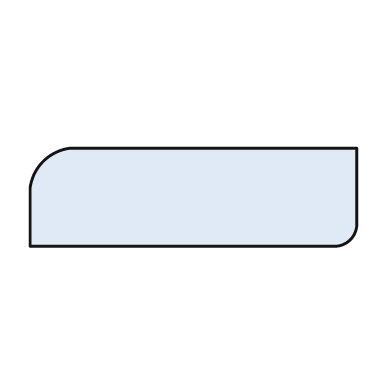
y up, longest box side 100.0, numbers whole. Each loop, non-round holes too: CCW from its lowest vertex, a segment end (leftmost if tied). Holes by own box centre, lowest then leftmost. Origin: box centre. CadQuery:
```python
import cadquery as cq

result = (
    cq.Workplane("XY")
    .moveTo(-50.0, -15.0)
    .lineTo(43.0, -15.0)
    .threePointArc((48.0, -13.0), (50.0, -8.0))
    .lineTo(50.0, 15.0)
    .lineTo(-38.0, 15.0)
    .threePointArc((-46.0, 11.0), (-50.0, 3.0))
    .close()
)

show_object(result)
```